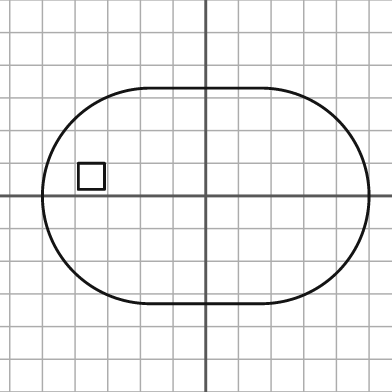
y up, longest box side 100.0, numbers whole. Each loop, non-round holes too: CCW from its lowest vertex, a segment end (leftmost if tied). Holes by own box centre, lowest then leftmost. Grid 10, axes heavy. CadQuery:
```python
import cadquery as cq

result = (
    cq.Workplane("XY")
    .moveTo(-17.0, -33.0)
    .lineTo(17.0, -33.0)
    .threePointArc((50.0, 0.0), (17.0, 33.0))
    .lineTo(-17.0, 33.0)
    .threePointArc((-50.0, 0.0), (-17.0, -33.0))
    .close()
    .moveTo(-39.0, 2.0)
    .lineTo(-31.0, 2.0)
    .lineTo(-31.0, 10.0)
    .lineTo(-39.0, 10.0)
    .close()
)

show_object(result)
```